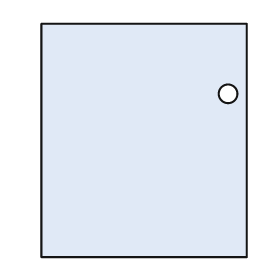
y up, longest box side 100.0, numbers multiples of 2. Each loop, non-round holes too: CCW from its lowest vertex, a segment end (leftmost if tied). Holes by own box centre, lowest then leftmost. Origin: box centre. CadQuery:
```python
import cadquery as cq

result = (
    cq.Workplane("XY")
    .moveTo(-44.0, -50.0)
    .lineTo(44.0, -50.0)
    .lineTo(44.0, 50.0)
    .lineTo(-44.0, 50.0)
    .close()
    .moveTo(36.0, 20.0)
    .circle(4.0)
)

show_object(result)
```